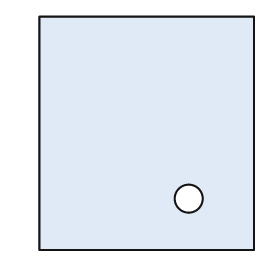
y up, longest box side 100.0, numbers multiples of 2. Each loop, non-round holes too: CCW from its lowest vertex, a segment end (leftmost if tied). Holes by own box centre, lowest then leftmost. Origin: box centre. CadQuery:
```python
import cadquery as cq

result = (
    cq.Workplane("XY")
    .moveTo(-46.0, -50.0)
    .lineTo(46.0, -50.0)
    .lineTo(46.0, 50.0)
    .lineTo(-46.0, 50.0)
    .close()
    .moveTo(18.0, -28.0)
    .circle(6.0)
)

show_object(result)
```